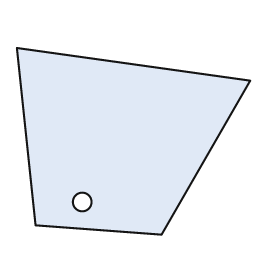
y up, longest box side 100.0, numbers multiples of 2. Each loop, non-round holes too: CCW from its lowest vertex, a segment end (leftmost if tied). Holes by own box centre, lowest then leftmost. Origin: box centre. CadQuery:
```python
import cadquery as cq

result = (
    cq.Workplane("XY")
    .moveTo(12.0, -40.0)
    .lineTo(50.0, 26.0)
    .lineTo(-50.0, 40.0)
    .lineTo(-42.0, -36.0)
    .close()
    .moveTo(-22.0, -26.0)
    .circle(4.0)
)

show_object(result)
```